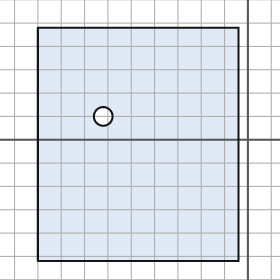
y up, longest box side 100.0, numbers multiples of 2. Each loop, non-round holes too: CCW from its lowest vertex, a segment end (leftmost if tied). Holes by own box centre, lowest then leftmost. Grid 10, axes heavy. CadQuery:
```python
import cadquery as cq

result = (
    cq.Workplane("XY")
    .moveTo(-90.0, -52.0)
    .lineTo(-4.0, -52.0)
    .lineTo(-4.0, 48.0)
    .lineTo(-90.0, 48.0)
    .close()
    .moveTo(-62.0, 10.0)
    .circle(4.0)
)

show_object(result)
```